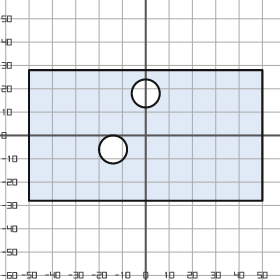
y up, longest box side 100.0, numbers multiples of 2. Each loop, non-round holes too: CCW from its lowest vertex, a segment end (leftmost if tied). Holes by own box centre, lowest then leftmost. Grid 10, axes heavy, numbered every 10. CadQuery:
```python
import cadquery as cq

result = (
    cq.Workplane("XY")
    .moveTo(-50.0, -28.0)
    .lineTo(50.0, -28.0)
    .lineTo(50.0, 28.0)
    .lineTo(-50.0, 28.0)
    .close()
    .moveTo(-14.0, -6.0)
    .circle(6.0)
    .moveTo(0.0, 18.0)
    .circle(6.0)
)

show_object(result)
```